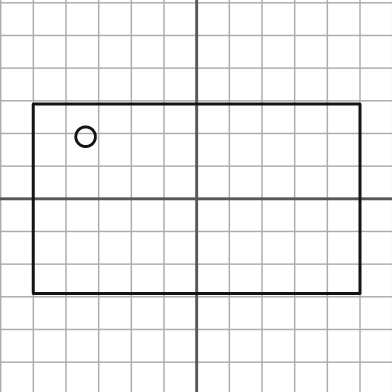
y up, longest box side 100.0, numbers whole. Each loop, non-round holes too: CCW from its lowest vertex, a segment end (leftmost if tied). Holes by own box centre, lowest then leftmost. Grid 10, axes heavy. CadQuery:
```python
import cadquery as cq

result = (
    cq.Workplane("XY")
    .moveTo(-50.0, -29.0)
    .lineTo(50.0, -29.0)
    .lineTo(50.0, 29.0)
    .lineTo(-50.0, 29.0)
    .close()
    .moveTo(-34.0, 19.0)
    .circle(3.0)
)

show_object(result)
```